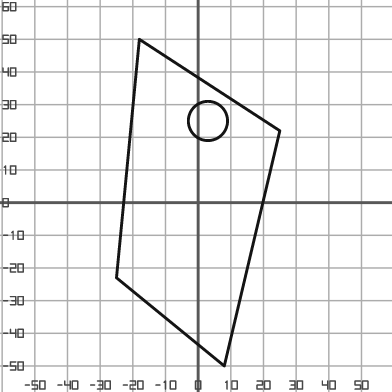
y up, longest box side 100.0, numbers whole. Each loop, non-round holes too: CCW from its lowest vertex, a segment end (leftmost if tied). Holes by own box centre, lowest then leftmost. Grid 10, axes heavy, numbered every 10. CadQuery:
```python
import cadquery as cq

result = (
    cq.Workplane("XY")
    .moveTo(8.0, -50.0)
    .lineTo(25.0, 22.0)
    .lineTo(-18.0, 50.0)
    .lineTo(-25.0, -23.0)
    .close()
    .moveTo(3.0, 25.0)
    .circle(6.0)
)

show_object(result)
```